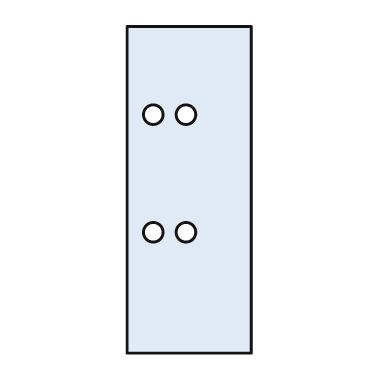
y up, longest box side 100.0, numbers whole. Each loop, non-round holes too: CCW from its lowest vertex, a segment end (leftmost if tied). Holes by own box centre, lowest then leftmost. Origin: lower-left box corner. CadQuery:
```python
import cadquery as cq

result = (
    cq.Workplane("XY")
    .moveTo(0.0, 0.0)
    .lineTo(38.0, 0.0)
    .lineTo(38.0, 100.0)
    .lineTo(0.0, 100.0)
    .close()
    .moveTo(8.0, 37.0)
    .circle(3.0)
    .moveTo(18.0, 37.0)
    .circle(3.0)
    .moveTo(8.0, 73.0)
    .circle(3.0)
    .moveTo(18.0, 73.0)
    .circle(3.0)
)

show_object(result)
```